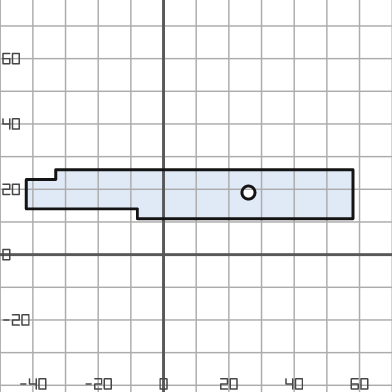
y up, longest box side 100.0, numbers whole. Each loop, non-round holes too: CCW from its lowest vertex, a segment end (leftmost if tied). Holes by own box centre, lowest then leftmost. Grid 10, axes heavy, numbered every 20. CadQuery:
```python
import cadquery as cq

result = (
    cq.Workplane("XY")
    .moveTo(-8.0, 11.0)
    .lineTo(58.0, 11.0)
    .lineTo(58.0, 26.0)
    .lineTo(-33.0, 26.0)
    .lineTo(-33.0, 23.0)
    .lineTo(-42.0, 23.0)
    .lineTo(-42.0, 14.0)
    .lineTo(-8.0, 14.0)
    .close()
    .moveTo(26.0, 19.0)
    .circle(2.0)
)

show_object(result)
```